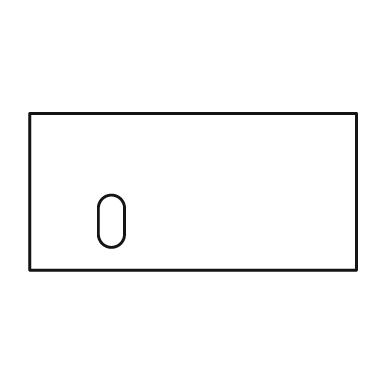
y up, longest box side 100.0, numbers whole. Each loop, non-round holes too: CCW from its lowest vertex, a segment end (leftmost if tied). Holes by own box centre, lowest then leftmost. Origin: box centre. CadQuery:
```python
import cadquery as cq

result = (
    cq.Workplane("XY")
    .moveTo(-50.0, -24.0)
    .lineTo(50.0, -24.0)
    .lineTo(50.0, 24.0)
    .lineTo(-50.0, 24.0)
    .close()
    .moveTo(-29.0, -13.0)
    .threePointArc((-25.0, -17.0), (-21.0, -13.0))
    .lineTo(-21.0, -5.0)
    .threePointArc((-25.0, -1.0), (-29.0, -5.0))
    .close()
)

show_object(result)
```